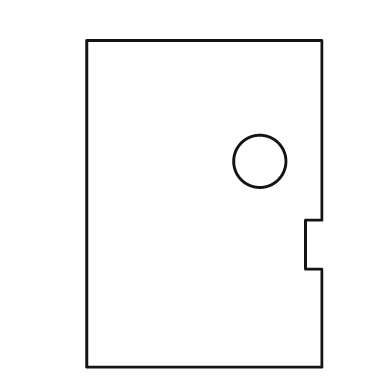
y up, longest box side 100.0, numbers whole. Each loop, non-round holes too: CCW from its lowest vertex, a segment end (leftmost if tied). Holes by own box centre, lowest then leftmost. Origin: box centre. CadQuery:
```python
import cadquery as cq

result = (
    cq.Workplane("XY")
    .moveTo(-36.0, -50.0)
    .lineTo(36.0, -50.0)
    .lineTo(36.0, -20.0)
    .lineTo(31.0, -20.0)
    .lineTo(31.0, -5.0)
    .lineTo(36.0, -5.0)
    .lineTo(36.0, 50.0)
    .lineTo(-36.0, 50.0)
    .close()
    .moveTo(17.0, 13.0)
    .circle(8.0)
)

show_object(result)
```